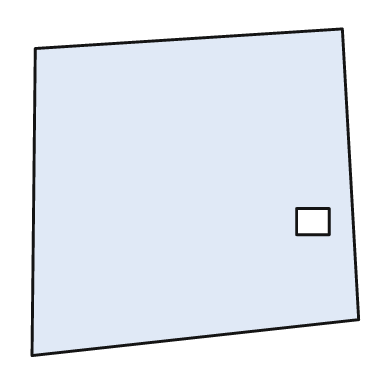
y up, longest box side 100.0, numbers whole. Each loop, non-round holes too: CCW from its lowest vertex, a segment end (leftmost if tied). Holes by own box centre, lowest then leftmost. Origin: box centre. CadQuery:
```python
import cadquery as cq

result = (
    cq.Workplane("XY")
    .moveTo(-50.0, -50.0)
    .lineTo(50.0, -39.0)
    .lineTo(45.0, 50.0)
    .lineTo(-49.0, 44.0)
    .close()
    .moveTo(31.0, -13.0)
    .lineTo(41.0, -13.0)
    .lineTo(41.0, -5.0)
    .lineTo(31.0, -5.0)
    .close()
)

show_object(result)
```